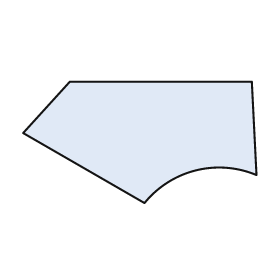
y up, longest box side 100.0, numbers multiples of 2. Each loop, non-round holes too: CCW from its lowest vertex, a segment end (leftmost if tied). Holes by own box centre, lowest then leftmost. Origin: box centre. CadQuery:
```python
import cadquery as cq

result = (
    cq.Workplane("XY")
    .moveTo(2.0, -26.0)
    .threePointArc((24.0, -12.0), (50.0, -14.0))
    .lineTo(48.0, 26.0)
    .lineTo(-30.0, 26.0)
    .lineTo(-50.0, 4.0)
    .close()
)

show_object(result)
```